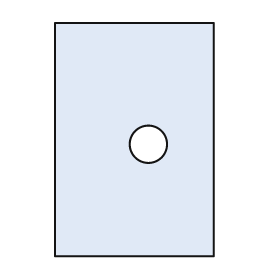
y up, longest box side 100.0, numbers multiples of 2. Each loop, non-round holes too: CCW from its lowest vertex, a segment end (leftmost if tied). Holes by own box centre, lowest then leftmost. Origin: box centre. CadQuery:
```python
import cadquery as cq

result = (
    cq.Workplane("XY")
    .moveTo(-34.0, -50.0)
    .lineTo(34.0, -50.0)
    .lineTo(34.0, 50.0)
    .lineTo(-34.0, 50.0)
    .close()
    .moveTo(6.0, -2.0)
    .circle(8.0)
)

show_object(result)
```